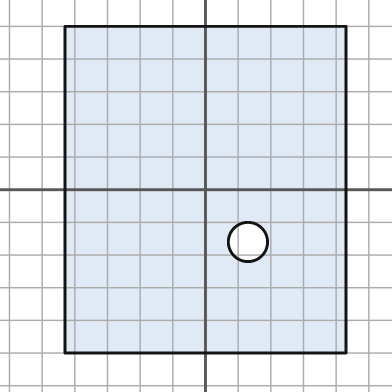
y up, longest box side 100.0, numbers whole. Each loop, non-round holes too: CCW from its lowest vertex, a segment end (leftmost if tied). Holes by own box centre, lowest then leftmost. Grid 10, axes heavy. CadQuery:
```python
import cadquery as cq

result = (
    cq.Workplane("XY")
    .moveTo(-43.0, -50.0)
    .lineTo(43.0, -50.0)
    .lineTo(43.0, 50.0)
    .lineTo(-43.0, 50.0)
    .close()
    .moveTo(13.0, -16.0)
    .circle(6.0)
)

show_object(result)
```